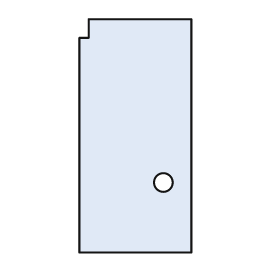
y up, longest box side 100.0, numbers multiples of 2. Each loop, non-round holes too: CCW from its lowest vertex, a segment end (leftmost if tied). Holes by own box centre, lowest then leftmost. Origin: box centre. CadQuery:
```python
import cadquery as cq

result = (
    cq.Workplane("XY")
    .moveTo(-24.0, -50.0)
    .lineTo(24.0, -50.0)
    .lineTo(24.0, 50.0)
    .lineTo(-20.0, 50.0)
    .lineTo(-20.0, 42.0)
    .lineTo(-24.0, 42.0)
    .close()
    .moveTo(12.0, -20.0)
    .circle(4.0)
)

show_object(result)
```